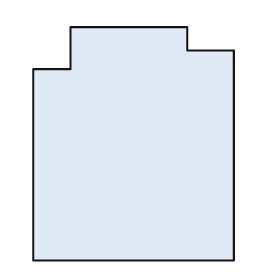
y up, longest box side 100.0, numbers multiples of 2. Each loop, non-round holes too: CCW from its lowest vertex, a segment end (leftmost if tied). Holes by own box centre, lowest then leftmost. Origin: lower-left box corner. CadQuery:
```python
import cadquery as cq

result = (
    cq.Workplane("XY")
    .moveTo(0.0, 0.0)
    .lineTo(86.0, 0.0)
    .lineTo(86.0, 90.0)
    .lineTo(66.0, 90.0)
    .lineTo(66.0, 100.0)
    .lineTo(16.0, 100.0)
    .lineTo(16.0, 82.0)
    .lineTo(0.0, 82.0)
    .close()
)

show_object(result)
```